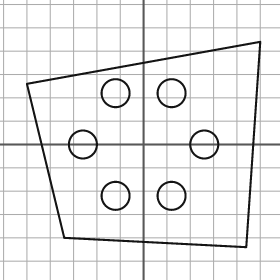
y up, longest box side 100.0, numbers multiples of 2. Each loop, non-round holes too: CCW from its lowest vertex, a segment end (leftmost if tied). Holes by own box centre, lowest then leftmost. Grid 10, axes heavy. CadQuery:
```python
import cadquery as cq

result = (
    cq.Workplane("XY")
    .moveTo(44.0, -44.0)
    .lineTo(50.0, 44.0)
    .lineTo(-50.0, 26.0)
    .lineTo(-34.0, -40.0)
    .close()
    .moveTo(-12.0, -22.0)
    .circle(6.0)
    .moveTo(12.0, -22.0)
    .circle(6.0)
    .moveTo(-26.0, 0.0)
    .circle(6.0)
    .moveTo(26.0, 0.0)
    .circle(6.0)
    .moveTo(-12.0, 22.0)
    .circle(6.0)
    .moveTo(12.0, 22.0)
    .circle(6.0)
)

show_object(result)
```